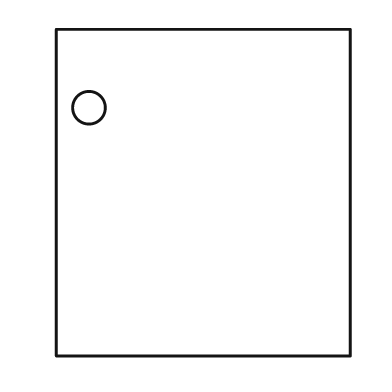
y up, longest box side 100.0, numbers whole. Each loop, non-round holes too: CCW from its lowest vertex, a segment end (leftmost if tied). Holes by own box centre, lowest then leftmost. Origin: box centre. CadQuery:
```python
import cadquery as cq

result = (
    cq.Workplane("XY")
    .moveTo(-45.0, -50.0)
    .lineTo(45.0, -50.0)
    .lineTo(45.0, 50.0)
    .lineTo(-45.0, 50.0)
    .close()
    .moveTo(-35.0, 26.0)
    .circle(5.0)
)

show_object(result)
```